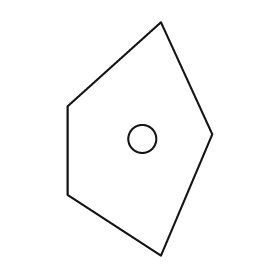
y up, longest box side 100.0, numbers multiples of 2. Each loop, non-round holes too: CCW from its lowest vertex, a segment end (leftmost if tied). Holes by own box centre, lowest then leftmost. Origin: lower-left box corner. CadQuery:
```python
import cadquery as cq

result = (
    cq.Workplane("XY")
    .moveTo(40.0, 0.0)
    .lineTo(62.0, 52.0)
    .lineTo(40.0, 100.0)
    .lineTo(0.0, 64.0)
    .lineTo(0.0, 26.0)
    .close()
    .moveTo(32.0, 50.0)
    .circle(6.0)
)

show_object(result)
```